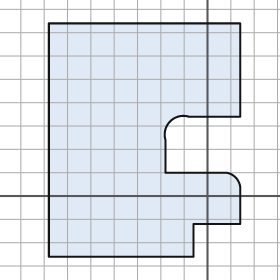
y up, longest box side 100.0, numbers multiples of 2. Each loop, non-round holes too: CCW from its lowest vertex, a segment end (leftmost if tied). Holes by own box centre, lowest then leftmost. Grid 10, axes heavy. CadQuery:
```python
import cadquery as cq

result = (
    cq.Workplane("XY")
    .moveTo(-68.0, -26.0)
    .lineTo(-6.0, -26.0)
    .lineTo(-6.0, -12.0)
    .lineTo(14.0, -12.0)
    .lineTo(14.0, 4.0)
    .threePointArc((12.0, 8.0), (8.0, 10.0))
    .lineTo(-18.0, 10.0)
    .lineTo(-18.0, 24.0)
    .threePointArc((-16.0, 32.0), (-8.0, 34.0))
    .lineTo(14.0, 34.0)
    .lineTo(14.0, 74.0)
    .lineTo(-68.0, 74.0)
    .close()
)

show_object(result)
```